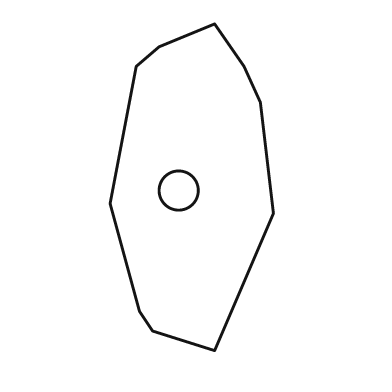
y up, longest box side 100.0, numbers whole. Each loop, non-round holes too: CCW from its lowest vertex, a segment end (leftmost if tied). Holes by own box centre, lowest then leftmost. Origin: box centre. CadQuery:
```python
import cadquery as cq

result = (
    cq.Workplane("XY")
    .moveTo(7.0, -50.0)
    .lineTo(25.0, -8.0)
    .lineTo(21.0, 26.0)
    .lineTo(16.0, 37.0)
    .lineTo(7.0, 50.0)
    .lineTo(-10.0, 43.0)
    .lineTo(-17.0, 37.0)
    .lineTo(-25.0, -5.0)
    .lineTo(-16.0, -38.0)
    .lineTo(-12.0, -44.0)
    .close()
    .moveTo(-4.0, -1.0)
    .circle(6.0)
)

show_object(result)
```